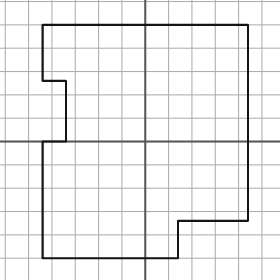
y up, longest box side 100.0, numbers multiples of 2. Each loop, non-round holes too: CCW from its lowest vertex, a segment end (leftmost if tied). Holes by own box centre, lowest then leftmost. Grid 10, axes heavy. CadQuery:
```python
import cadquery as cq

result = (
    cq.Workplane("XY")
    .moveTo(-44.0, -50.0)
    .lineTo(14.0, -50.0)
    .lineTo(14.0, -34.0)
    .lineTo(44.0, -34.0)
    .lineTo(44.0, 50.0)
    .lineTo(-44.0, 50.0)
    .lineTo(-44.0, 26.0)
    .lineTo(-34.0, 26.0)
    .lineTo(-34.0, 0.0)
    .lineTo(-44.0, 0.0)
    .close()
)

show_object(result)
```